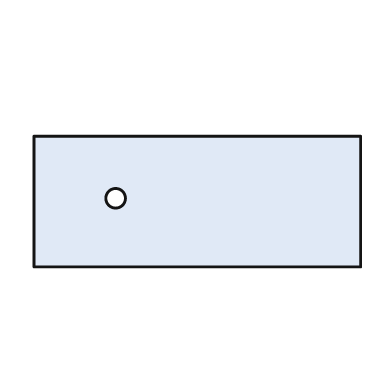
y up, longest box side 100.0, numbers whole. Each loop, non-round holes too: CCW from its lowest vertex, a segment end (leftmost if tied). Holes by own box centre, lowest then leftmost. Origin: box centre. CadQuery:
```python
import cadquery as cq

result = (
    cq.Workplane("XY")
    .moveTo(-50.0, -20.0)
    .lineTo(50.0, -20.0)
    .lineTo(50.0, 20.0)
    .lineTo(-50.0, 20.0)
    .close()
    .moveTo(-25.0, 1.0)
    .circle(3.0)
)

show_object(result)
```